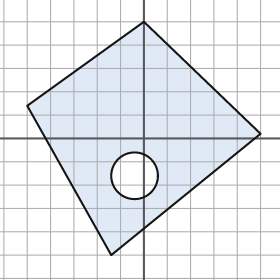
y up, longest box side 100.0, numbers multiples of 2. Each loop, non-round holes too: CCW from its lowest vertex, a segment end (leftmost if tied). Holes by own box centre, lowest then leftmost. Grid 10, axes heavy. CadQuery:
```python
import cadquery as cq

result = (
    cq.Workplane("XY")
    .moveTo(-14.0, -50.0)
    .lineTo(50.0, 2.0)
    .lineTo(0.0, 50.0)
    .lineTo(-50.0, 14.0)
    .close()
    .moveTo(-4.0, -16.0)
    .circle(10.0)
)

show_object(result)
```